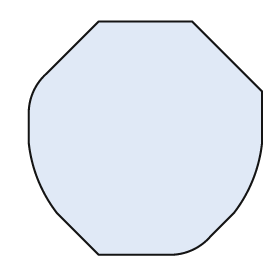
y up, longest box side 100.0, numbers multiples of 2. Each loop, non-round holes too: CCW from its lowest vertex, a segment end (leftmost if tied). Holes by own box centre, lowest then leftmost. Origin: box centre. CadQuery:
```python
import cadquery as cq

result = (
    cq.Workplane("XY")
    .moveTo(-20.0, -50.0)
    .lineTo(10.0, -50.0)
    .threePointArc((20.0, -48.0), (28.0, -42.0))
    .lineTo(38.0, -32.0)
    .threePointArc((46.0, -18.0), (50.0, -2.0))
    .lineTo(50.0, 20.0)
    .lineTo(20.0, 50.0)
    .lineTo(-20.0, 50.0)
    .lineTo(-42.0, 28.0)
    .threePointArc((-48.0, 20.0), (-50.0, 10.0))
    .lineTo(-50.0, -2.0)
    .threePointArc((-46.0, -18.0), (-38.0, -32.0))
    .close()
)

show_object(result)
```